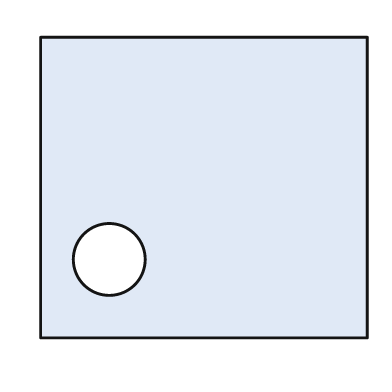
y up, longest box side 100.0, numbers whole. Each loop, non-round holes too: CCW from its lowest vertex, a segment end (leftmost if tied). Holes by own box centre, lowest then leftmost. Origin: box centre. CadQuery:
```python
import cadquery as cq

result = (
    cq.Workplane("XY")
    .moveTo(-50.0, -46.0)
    .lineTo(50.0, -46.0)
    .lineTo(50.0, 46.0)
    .lineTo(-50.0, 46.0)
    .close()
    .moveTo(-29.0, -22.0)
    .circle(11.0)
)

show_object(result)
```